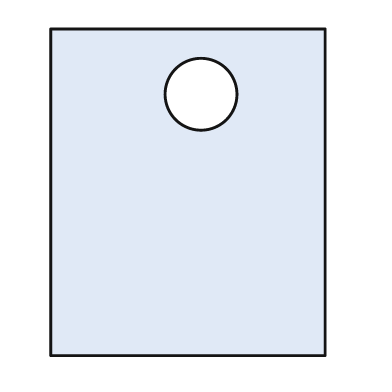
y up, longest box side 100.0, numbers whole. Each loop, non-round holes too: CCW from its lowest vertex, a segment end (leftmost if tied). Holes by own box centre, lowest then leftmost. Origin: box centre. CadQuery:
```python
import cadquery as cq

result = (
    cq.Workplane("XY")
    .moveTo(-42.0, -50.0)
    .lineTo(42.0, -50.0)
    .lineTo(42.0, 50.0)
    .lineTo(-42.0, 50.0)
    .close()
    .moveTo(4.0, 30.0)
    .circle(11.0)
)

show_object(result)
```